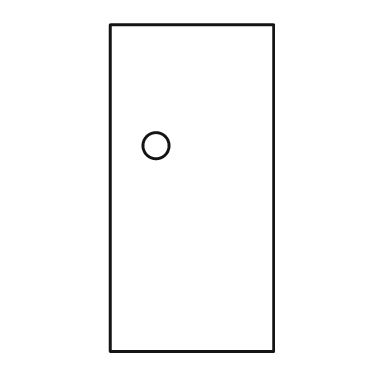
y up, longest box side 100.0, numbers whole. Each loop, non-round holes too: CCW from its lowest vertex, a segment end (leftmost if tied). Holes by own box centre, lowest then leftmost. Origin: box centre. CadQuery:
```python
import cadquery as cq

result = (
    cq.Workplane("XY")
    .moveTo(-25.0, -50.0)
    .lineTo(25.0, -50.0)
    .lineTo(25.0, 50.0)
    .lineTo(-25.0, 50.0)
    .close()
    .moveTo(-11.0, 13.0)
    .circle(4.0)
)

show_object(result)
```